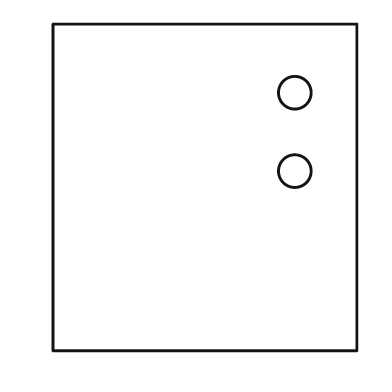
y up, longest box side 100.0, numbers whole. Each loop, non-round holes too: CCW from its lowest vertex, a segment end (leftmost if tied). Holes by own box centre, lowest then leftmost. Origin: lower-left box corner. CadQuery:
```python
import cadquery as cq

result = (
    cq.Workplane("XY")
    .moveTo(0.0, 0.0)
    .lineTo(93.0, 0.0)
    .lineTo(93.0, 100.0)
    .lineTo(0.0, 100.0)
    .close()
    .moveTo(74.0, 55.0)
    .circle(5.0)
    .moveTo(74.0, 79.0)
    .circle(5.0)
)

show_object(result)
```